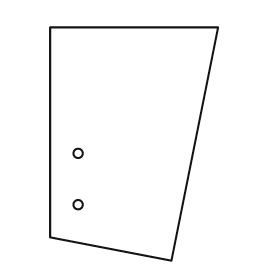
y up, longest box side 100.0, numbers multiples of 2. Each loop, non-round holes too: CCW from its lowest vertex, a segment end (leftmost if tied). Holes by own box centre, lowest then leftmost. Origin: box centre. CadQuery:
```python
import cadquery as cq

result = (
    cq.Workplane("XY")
    .moveTo(16.0, -50.0)
    .lineTo(36.0, 50.0)
    .lineTo(-36.0, 50.0)
    .lineTo(-36.0, -40.0)
    .close()
    .moveTo(-24.0, -26.0)
    .circle(2.0)
    .moveTo(-24.0, -4.0)
    .circle(2.0)
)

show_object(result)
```